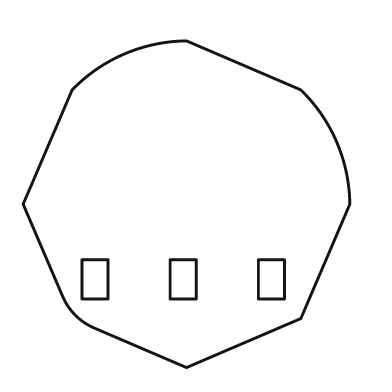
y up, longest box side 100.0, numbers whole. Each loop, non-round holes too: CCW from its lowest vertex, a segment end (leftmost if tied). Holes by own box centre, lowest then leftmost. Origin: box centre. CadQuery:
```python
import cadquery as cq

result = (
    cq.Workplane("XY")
    .moveTo(0.0, -50.0)
    .lineTo(35.0, -35.0)
    .lineTo(50.0, 0.0)
    .threePointArc((46.0, 19.0), (35.0, 35.0))
    .lineTo(0.0, 50.0)
    .threePointArc((-19.0, 46.0), (-35.0, 35.0))
    .lineTo(-50.0, 0.0)
    .lineTo(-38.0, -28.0)
    .threePointArc((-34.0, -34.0), (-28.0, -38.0))
    .close()
    .moveTo(-32.0, -29.0)
    .lineTo(-24.0, -29.0)
    .lineTo(-24.0, -17.0)
    .lineTo(-32.0, -17.0)
    .close()
    .moveTo(-5.0, -29.0)
    .lineTo(3.0, -29.0)
    .lineTo(3.0, -17.0)
    .lineTo(-5.0, -17.0)
    .close()
    .moveTo(22.0, -29.0)
    .lineTo(30.0, -29.0)
    .lineTo(30.0, -17.0)
    .lineTo(22.0, -17.0)
    .close()
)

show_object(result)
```